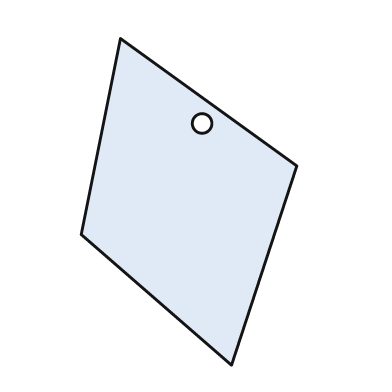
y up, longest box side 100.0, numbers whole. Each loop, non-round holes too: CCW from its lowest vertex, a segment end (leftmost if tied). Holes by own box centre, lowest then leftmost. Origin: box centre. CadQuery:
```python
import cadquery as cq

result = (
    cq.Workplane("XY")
    .moveTo(13.0, -50.0)
    .lineTo(33.0, 11.0)
    .lineTo(-21.0, 50.0)
    .lineTo(-33.0, -10.0)
    .close()
    .moveTo(4.0, 24.0)
    .circle(3.0)
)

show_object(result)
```